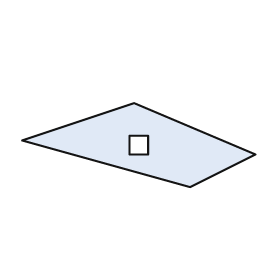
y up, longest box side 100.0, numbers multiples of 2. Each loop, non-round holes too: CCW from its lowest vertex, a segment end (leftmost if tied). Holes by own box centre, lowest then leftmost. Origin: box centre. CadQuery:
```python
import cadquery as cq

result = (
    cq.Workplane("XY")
    .moveTo(22.0, -18.0)
    .lineTo(50.0, -4.0)
    .lineTo(-2.0, 18.0)
    .lineTo(-50.0, 2.0)
    .close()
    .moveTo(-4.0, -4.0)
    .lineTo(4.0, -4.0)
    .lineTo(4.0, 4.0)
    .lineTo(-4.0, 4.0)
    .close()
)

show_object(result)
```